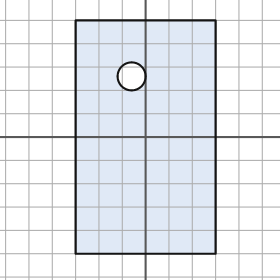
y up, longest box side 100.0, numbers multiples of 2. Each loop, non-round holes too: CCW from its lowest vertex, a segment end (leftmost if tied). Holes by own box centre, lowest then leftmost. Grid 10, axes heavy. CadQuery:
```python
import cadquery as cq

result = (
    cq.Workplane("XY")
    .moveTo(-30.0, -50.0)
    .lineTo(30.0, -50.0)
    .lineTo(30.0, 50.0)
    .lineTo(-30.0, 50.0)
    .close()
    .moveTo(-6.0, 26.0)
    .circle(6.0)
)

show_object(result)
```